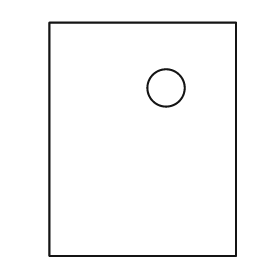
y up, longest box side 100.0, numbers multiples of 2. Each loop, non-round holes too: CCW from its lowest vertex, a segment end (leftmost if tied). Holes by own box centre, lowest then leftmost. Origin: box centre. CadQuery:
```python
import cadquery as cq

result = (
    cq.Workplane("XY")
    .moveTo(-40.0, -50.0)
    .lineTo(40.0, -50.0)
    .lineTo(40.0, 50.0)
    .lineTo(-40.0, 50.0)
    .close()
    .moveTo(10.0, 22.0)
    .circle(8.0)
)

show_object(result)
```